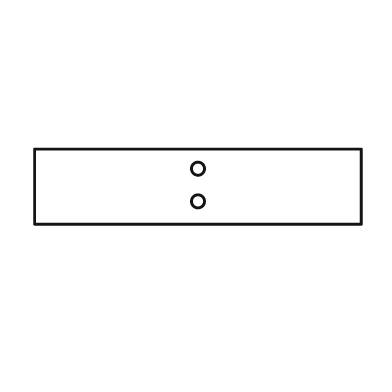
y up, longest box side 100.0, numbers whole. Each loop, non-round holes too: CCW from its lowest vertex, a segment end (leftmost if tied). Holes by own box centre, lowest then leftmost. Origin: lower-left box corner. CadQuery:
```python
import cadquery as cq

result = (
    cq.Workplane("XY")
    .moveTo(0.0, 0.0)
    .lineTo(100.0, 0.0)
    .lineTo(100.0, 23.0)
    .lineTo(0.0, 23.0)
    .close()
    .moveTo(50.0, 7.0)
    .circle(2.0)
    .moveTo(50.0, 17.0)
    .circle(2.0)
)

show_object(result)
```